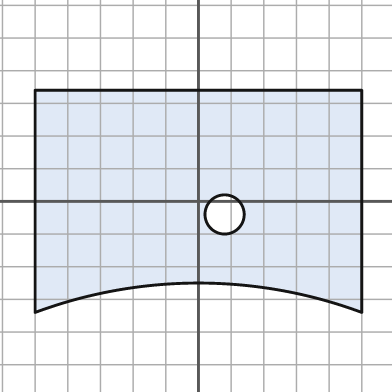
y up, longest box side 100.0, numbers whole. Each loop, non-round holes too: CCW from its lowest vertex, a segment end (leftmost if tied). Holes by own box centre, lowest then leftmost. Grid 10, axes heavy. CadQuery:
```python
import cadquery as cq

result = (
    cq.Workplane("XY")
    .moveTo(-50.0, -34.0)
    .threePointArc((0.0, -25.0), (50.0, -34.0))
    .lineTo(50.0, 34.0)
    .lineTo(-50.0, 34.0)
    .close()
    .moveTo(8.0, -4.0)
    .circle(6.0)
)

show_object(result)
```